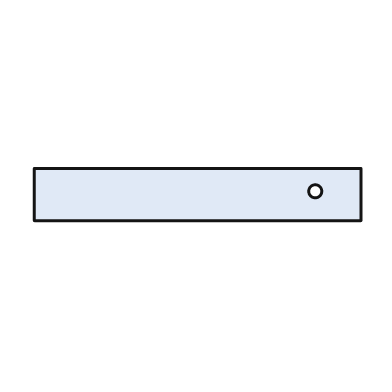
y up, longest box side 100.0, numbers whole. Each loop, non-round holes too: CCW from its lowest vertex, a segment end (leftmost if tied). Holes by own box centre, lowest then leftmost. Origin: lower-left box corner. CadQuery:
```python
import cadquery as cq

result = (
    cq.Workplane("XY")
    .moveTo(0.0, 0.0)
    .lineTo(100.0, 0.0)
    .lineTo(100.0, 16.0)
    .lineTo(0.0, 16.0)
    .close()
    .moveTo(86.0, 9.0)
    .circle(2.0)
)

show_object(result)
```